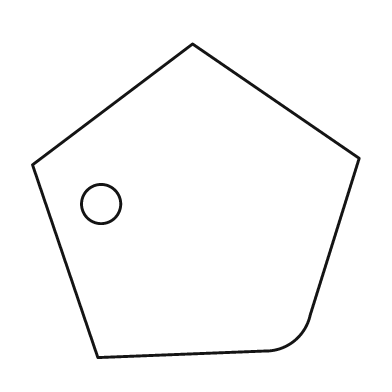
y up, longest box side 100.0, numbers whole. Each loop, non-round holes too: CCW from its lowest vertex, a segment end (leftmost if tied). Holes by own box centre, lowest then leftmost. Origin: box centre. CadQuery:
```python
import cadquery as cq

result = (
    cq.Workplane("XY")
    .moveTo(-30.0, -48.0)
    .lineTo(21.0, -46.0)
    .threePointArc((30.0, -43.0), (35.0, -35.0))
    .lineTo(50.0, 13.0)
    .lineTo(-1.0, 48.0)
    .lineTo(-50.0, 11.0)
    .close()
    .moveTo(-29.0, -1.0)
    .circle(6.0)
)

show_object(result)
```